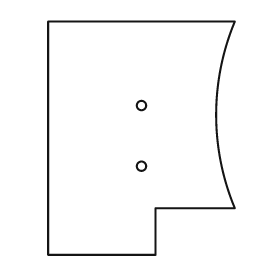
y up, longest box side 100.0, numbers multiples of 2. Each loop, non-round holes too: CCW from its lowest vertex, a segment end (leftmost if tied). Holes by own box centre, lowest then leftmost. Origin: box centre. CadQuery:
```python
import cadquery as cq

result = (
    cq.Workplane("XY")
    .moveTo(-40.0, -50.0)
    .lineTo(6.0, -50.0)
    .lineTo(6.0, -30.0)
    .lineTo(40.0, -30.0)
    .threePointArc((32.0, 10.0), (40.0, 50.0))
    .lineTo(-40.0, 50.0)
    .close()
    .moveTo(0.0, -12.0)
    .circle(2.0)
    .moveTo(0.0, 14.0)
    .circle(2.0)
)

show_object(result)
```